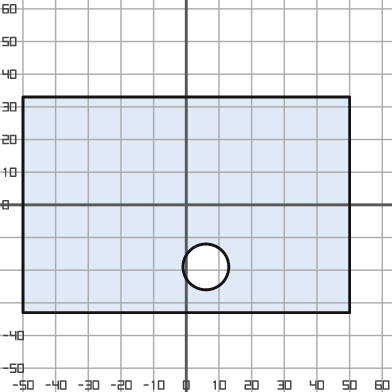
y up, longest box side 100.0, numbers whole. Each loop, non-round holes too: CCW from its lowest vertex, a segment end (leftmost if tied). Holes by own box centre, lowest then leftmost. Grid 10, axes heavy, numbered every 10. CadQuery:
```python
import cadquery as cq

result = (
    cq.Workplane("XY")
    .moveTo(-50.0, -33.0)
    .lineTo(50.0, -33.0)
    .lineTo(50.0, 33.0)
    .lineTo(-50.0, 33.0)
    .close()
    .moveTo(6.0, -19.0)
    .circle(7.0)
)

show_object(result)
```